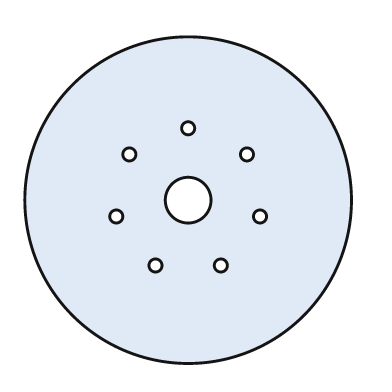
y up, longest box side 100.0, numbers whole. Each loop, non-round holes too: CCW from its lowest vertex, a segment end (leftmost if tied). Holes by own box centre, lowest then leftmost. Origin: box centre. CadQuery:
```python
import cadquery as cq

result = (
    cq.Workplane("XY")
    .moveTo(0.0, 0.0)
    .circle(50.0)
    .moveTo(-10.0, -20.0)
    .circle(2.0)
    .moveTo(10.0, -20.0)
    .circle(2.0)
    .moveTo(-22.0, -5.0)
    .circle(2.0)
    .moveTo(22.0, -5.0)
    .circle(2.0)
    .moveTo(0.0, 0.0)
    .circle(7.0)
    .moveTo(-18.0, 14.0)
    .circle(2.0)
    .moveTo(18.0, 14.0)
    .circle(2.0)
    .moveTo(0.0, 22.0)
    .circle(2.0)
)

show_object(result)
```